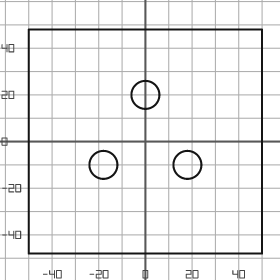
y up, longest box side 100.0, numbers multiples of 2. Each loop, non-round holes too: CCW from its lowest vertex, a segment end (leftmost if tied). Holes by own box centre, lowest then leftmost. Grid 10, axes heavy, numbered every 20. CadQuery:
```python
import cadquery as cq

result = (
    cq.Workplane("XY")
    .moveTo(-50.0, -48.0)
    .lineTo(50.0, -48.0)
    .lineTo(50.0, 48.0)
    .lineTo(-50.0, 48.0)
    .close()
    .moveTo(-18.0, -10.0)
    .circle(6.0)
    .moveTo(18.0, -10.0)
    .circle(6.0)
    .moveTo(0.0, 20.0)
    .circle(6.0)
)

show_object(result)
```